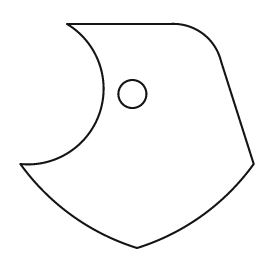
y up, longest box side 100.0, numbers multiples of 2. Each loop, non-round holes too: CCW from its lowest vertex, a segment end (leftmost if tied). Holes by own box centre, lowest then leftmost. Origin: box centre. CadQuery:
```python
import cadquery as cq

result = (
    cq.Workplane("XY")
    .moveTo(0.0, -48.0)
    .threePointArc((28.0, -34.0), (50.0, -12.0))
    .lineTo(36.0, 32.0)
    .threePointArc((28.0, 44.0), (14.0, 48.0))
    .lineTo(-30.0, 48.0)
    .threePointArc((-16.0, 10.0), (-50.0, -12.0))
    .threePointArc((-28.0, -34.0), (0.0, -48.0))
    .close()
    .moveTo(-2.0, 18.0)
    .circle(6.0)
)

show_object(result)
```